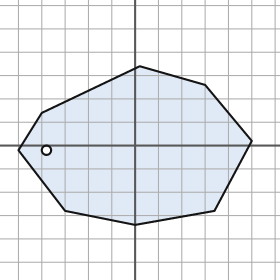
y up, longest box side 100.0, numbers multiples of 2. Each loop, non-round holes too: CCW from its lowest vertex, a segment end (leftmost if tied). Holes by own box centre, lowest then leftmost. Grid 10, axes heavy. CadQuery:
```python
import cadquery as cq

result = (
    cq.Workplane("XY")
    .moveTo(0.0, -34.0)
    .lineTo(34.0, -28.0)
    .lineTo(50.0, 2.0)
    .lineTo(30.0, 26.0)
    .lineTo(2.0, 34.0)
    .lineTo(-40.0, 14.0)
    .lineTo(-50.0, -2.0)
    .lineTo(-30.0, -28.0)
    .close()
    .moveTo(-38.0, -2.0)
    .circle(2.0)
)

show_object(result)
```